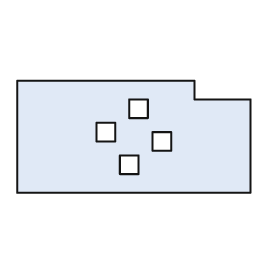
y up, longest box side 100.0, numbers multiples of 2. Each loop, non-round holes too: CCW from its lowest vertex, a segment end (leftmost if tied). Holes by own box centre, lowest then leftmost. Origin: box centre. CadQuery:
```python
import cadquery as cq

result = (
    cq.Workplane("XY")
    .moveTo(-50.0, -24.0)
    .lineTo(50.0, -24.0)
    .lineTo(50.0, 16.0)
    .lineTo(26.0, 16.0)
    .lineTo(26.0, 24.0)
    .lineTo(-50.0, 24.0)
    .close()
    .moveTo(-6.0, -16.0)
    .lineTo(2.0, -16.0)
    .lineTo(2.0, -8.0)
    .lineTo(-6.0, -8.0)
    .close()
    .moveTo(8.0, -6.0)
    .lineTo(16.0, -6.0)
    .lineTo(16.0, 2.0)
    .lineTo(8.0, 2.0)
    .close()
    .moveTo(-16.0, -2.0)
    .lineTo(-8.0, -2.0)
    .lineTo(-8.0, 6.0)
    .lineTo(-16.0, 6.0)
    .close()
    .moveTo(-2.0, 8.0)
    .lineTo(6.0, 8.0)
    .lineTo(6.0, 16.0)
    .lineTo(-2.0, 16.0)
    .close()
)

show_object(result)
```